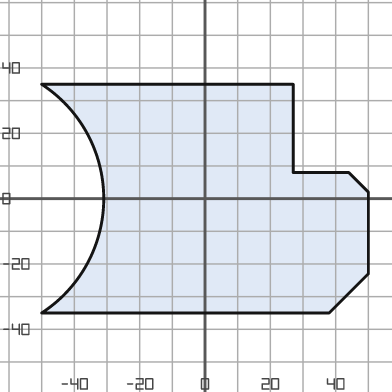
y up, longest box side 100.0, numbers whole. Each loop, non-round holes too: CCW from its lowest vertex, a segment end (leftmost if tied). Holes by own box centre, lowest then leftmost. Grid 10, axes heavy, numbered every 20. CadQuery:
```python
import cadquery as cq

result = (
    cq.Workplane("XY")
    .moveTo(-50.0, -35.0)
    .lineTo(38.0, -35.0)
    .lineTo(50.0, -23.0)
    .lineTo(50.0, 2.0)
    .lineTo(44.0, 8.0)
    .lineTo(27.0, 8.0)
    .lineTo(27.0, 35.0)
    .lineTo(-50.0, 35.0)
    .threePointArc((-31.0, 0.0), (-50.0, -35.0))
    .close()
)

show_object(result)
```